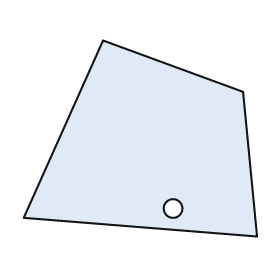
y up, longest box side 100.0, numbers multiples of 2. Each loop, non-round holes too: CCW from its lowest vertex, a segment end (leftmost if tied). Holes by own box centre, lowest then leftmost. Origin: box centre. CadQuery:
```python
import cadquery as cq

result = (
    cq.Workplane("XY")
    .moveTo(50.0, -42.0)
    .lineTo(44.0, 20.0)
    .lineTo(-16.0, 42.0)
    .lineTo(-50.0, -34.0)
    .close()
    .moveTo(14.0, -30.0)
    .circle(4.0)
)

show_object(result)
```